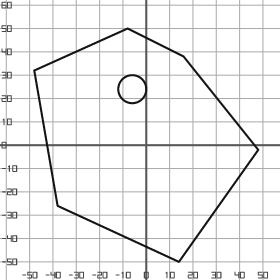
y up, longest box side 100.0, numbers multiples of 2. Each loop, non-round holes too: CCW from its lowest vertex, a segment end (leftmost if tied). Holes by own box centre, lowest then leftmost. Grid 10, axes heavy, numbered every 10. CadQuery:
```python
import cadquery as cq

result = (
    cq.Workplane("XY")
    .moveTo(14.0, -50.0)
    .lineTo(48.0, -2.0)
    .lineTo(16.0, 38.0)
    .lineTo(-8.0, 50.0)
    .lineTo(-48.0, 32.0)
    .lineTo(-38.0, -26.0)
    .close()
    .moveTo(-6.0, 24.0)
    .circle(6.0)
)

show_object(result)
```